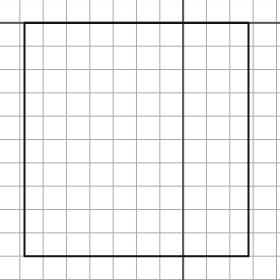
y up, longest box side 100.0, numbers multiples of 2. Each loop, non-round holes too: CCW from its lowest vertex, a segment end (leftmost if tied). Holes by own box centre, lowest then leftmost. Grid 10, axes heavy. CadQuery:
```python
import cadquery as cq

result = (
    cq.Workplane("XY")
    .moveTo(-68.0, -100.0)
    .lineTo(28.0, -100.0)
    .lineTo(28.0, 0.0)
    .lineTo(-68.0, 0.0)
    .close()
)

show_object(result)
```